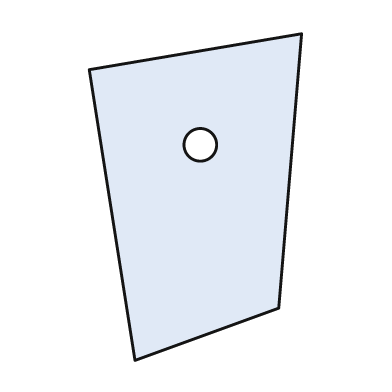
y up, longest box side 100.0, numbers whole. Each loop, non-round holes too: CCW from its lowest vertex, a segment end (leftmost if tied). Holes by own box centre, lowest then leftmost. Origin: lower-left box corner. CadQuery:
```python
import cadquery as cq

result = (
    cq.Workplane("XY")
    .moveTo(14.0, 0.0)
    .lineTo(58.0, 16.0)
    .lineTo(65.0, 100.0)
    .lineTo(0.0, 89.0)
    .close()
    .moveTo(34.0, 66.0)
    .circle(5.0)
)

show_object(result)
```